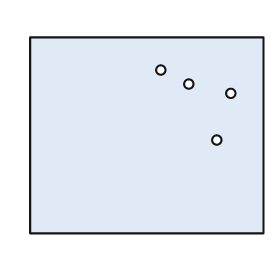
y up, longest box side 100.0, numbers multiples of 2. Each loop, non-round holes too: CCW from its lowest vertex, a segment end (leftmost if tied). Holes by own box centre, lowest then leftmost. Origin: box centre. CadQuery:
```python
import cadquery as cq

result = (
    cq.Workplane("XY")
    .moveTo(-50.0, -42.0)
    .lineTo(50.0, -42.0)
    .lineTo(50.0, 42.0)
    .lineTo(-50.0, 42.0)
    .close()
    .moveTo(30.0, -2.0)
    .circle(2.0)
    .moveTo(36.0, 18.0)
    .circle(2.0)
    .moveTo(18.0, 22.0)
    .circle(2.0)
    .moveTo(6.0, 28.0)
    .circle(2.0)
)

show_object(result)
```